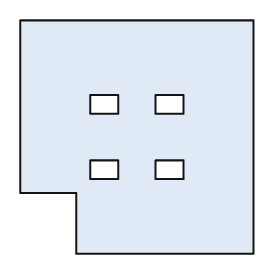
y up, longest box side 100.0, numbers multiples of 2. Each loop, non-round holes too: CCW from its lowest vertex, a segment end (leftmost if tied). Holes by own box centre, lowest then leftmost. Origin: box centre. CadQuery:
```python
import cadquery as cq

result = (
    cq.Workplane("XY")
    .moveTo(-26.0, -50.0)
    .lineTo(50.0, -50.0)
    .lineTo(50.0, 50.0)
    .lineTo(-50.0, 50.0)
    .lineTo(-50.0, -24.0)
    .lineTo(-26.0, -24.0)
    .close()
    .moveTo(-20.0, -18.0)
    .lineTo(-8.0, -18.0)
    .lineTo(-8.0, -10.0)
    .lineTo(-20.0, -10.0)
    .close()
    .moveTo(8.0, -18.0)
    .lineTo(20.0, -18.0)
    .lineTo(20.0, -10.0)
    .lineTo(8.0, -10.0)
    .close()
    .moveTo(-20.0, 10.0)
    .lineTo(-8.0, 10.0)
    .lineTo(-8.0, 18.0)
    .lineTo(-20.0, 18.0)
    .close()
    .moveTo(8.0, 10.0)
    .lineTo(20.0, 10.0)
    .lineTo(20.0, 18.0)
    .lineTo(8.0, 18.0)
    .close()
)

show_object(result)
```